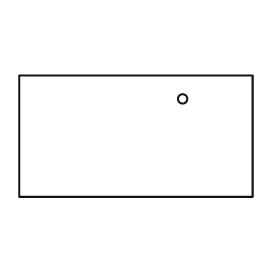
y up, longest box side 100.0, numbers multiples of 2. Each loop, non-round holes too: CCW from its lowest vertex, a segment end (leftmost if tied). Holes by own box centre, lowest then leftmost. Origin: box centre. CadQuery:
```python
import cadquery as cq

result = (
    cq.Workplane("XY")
    .moveTo(-50.0, -26.0)
    .lineTo(50.0, -26.0)
    .lineTo(50.0, 26.0)
    .lineTo(-50.0, 26.0)
    .close()
    .moveTo(20.0, 16.0)
    .circle(2.0)
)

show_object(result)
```